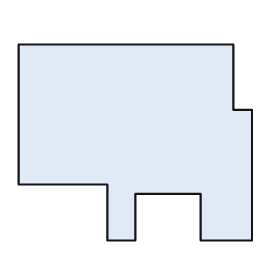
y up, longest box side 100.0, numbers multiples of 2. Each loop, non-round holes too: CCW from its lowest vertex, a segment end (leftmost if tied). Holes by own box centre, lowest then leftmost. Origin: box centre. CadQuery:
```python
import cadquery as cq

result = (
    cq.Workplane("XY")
    .moveTo(-12.0, -42.0)
    .lineTo(0.0, -42.0)
    .lineTo(0.0, -22.0)
    .lineTo(28.0, -22.0)
    .lineTo(28.0, -42.0)
    .lineTo(50.0, -42.0)
    .lineTo(50.0, 14.0)
    .lineTo(42.0, 14.0)
    .lineTo(42.0, 42.0)
    .lineTo(-50.0, 42.0)
    .lineTo(-50.0, -18.0)
    .lineTo(-12.0, -18.0)
    .close()
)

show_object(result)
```